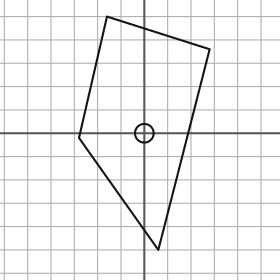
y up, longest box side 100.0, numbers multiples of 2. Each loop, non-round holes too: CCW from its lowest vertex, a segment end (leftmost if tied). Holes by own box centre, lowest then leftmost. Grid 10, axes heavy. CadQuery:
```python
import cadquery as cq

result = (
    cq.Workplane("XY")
    .moveTo(6.0, -50.0)
    .lineTo(28.0, 36.0)
    .lineTo(-16.0, 50.0)
    .lineTo(-28.0, -2.0)
    .close()
    .moveTo(0.0, 0.0)
    .circle(4.0)
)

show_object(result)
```